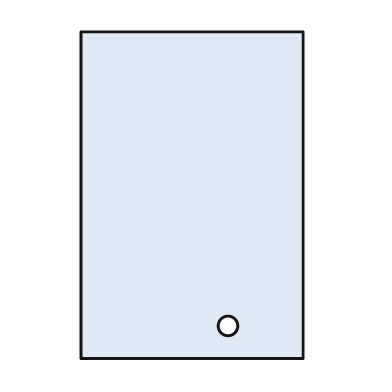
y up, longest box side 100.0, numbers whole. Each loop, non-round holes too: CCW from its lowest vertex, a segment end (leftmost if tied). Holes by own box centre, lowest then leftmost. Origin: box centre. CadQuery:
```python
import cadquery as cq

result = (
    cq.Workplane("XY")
    .moveTo(-34.0, -50.0)
    .lineTo(34.0, -50.0)
    .lineTo(34.0, 50.0)
    .lineTo(-34.0, 50.0)
    .close()
    .moveTo(11.0, -40.0)
    .circle(3.0)
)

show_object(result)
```